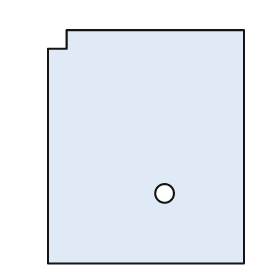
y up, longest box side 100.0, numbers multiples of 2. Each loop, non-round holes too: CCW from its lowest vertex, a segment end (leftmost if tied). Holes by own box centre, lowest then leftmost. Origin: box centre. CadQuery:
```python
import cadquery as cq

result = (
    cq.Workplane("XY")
    .moveTo(-42.0, -50.0)
    .lineTo(42.0, -50.0)
    .lineTo(42.0, 50.0)
    .lineTo(-34.0, 50.0)
    .lineTo(-34.0, 42.0)
    .lineTo(-42.0, 42.0)
    .close()
    .moveTo(8.0, -20.0)
    .circle(4.0)
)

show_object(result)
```